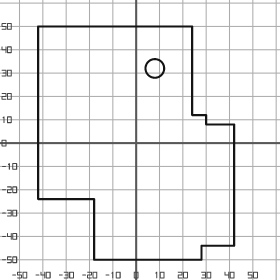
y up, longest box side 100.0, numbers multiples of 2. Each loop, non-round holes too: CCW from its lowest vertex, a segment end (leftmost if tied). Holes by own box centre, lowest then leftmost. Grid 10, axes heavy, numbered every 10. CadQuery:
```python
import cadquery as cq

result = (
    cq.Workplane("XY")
    .moveTo(-18.0, -50.0)
    .lineTo(28.0, -50.0)
    .lineTo(28.0, -44.0)
    .lineTo(42.0, -44.0)
    .lineTo(42.0, 8.0)
    .lineTo(30.0, 8.0)
    .lineTo(30.0, 12.0)
    .lineTo(24.0, 12.0)
    .lineTo(24.0, 50.0)
    .lineTo(-42.0, 50.0)
    .lineTo(-42.0, -24.0)
    .lineTo(-18.0, -24.0)
    .close()
    .moveTo(8.0, 32.0)
    .circle(4.0)
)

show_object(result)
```